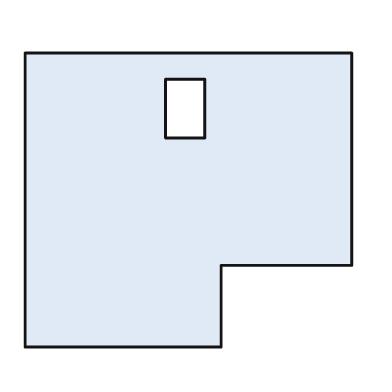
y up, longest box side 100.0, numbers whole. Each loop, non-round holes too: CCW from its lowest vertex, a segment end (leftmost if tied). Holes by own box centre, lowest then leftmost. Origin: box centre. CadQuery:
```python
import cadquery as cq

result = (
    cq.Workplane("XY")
    .moveTo(-50.0, -45.0)
    .lineTo(10.0, -45.0)
    .lineTo(10.0, -20.0)
    .lineTo(50.0, -20.0)
    .lineTo(50.0, 45.0)
    .lineTo(-50.0, 45.0)
    .close()
    .moveTo(-7.0, 19.0)
    .lineTo(5.0, 19.0)
    .lineTo(5.0, 37.0)
    .lineTo(-7.0, 37.0)
    .close()
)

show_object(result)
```